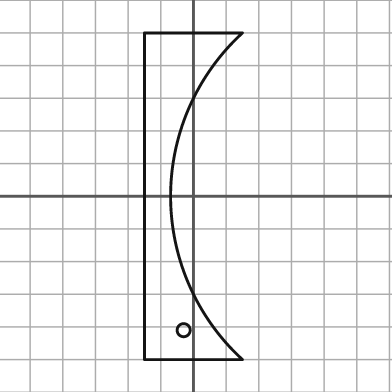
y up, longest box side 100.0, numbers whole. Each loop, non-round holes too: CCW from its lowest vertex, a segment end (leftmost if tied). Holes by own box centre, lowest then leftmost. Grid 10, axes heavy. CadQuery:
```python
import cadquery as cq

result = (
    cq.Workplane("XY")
    .moveTo(-15.0, -50.0)
    .lineTo(15.0, -50.0)
    .threePointArc((-7.0, 0.0), (15.0, 50.0))
    .lineTo(-15.0, 50.0)
    .close()
    .moveTo(-3.0, -41.0)
    .circle(2.0)
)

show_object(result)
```